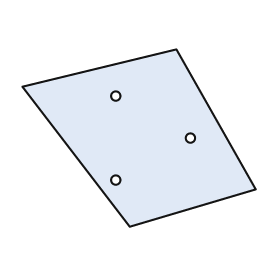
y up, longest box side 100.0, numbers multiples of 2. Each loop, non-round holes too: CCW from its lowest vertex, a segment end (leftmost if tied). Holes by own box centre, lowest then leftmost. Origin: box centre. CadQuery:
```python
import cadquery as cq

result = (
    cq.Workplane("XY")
    .moveTo(-4.0, -38.0)
    .lineTo(50.0, -22.0)
    .lineTo(16.0, 38.0)
    .lineTo(-50.0, 22.0)
    .close()
    .moveTo(-10.0, -18.0)
    .circle(2.0)
    .moveTo(22.0, 0.0)
    .circle(2.0)
    .moveTo(-10.0, 18.0)
    .circle(2.0)
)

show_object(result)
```